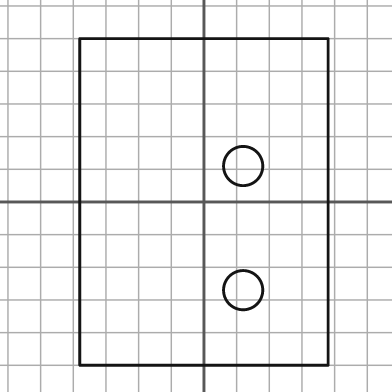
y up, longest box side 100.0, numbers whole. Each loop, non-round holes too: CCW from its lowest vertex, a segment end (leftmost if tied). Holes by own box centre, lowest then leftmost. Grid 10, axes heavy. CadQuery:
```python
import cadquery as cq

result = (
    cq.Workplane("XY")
    .moveTo(-38.0, -50.0)
    .lineTo(38.0, -50.0)
    .lineTo(38.0, 50.0)
    .lineTo(-38.0, 50.0)
    .close()
    .moveTo(12.0, -27.0)
    .circle(6.0)
    .moveTo(12.0, 11.0)
    .circle(6.0)
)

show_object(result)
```